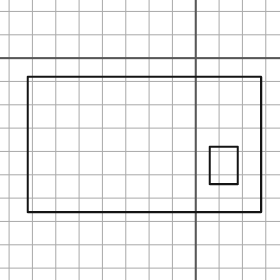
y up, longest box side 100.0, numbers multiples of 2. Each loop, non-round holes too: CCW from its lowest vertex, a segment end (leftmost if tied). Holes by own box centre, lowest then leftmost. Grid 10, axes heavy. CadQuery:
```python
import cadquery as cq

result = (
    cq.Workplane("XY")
    .moveTo(-72.0, -66.0)
    .lineTo(28.0, -66.0)
    .lineTo(28.0, -8.0)
    .lineTo(-72.0, -8.0)
    .close()
    .moveTo(6.0, -54.0)
    .lineTo(18.0, -54.0)
    .lineTo(18.0, -38.0)
    .lineTo(6.0, -38.0)
    .close()
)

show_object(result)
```